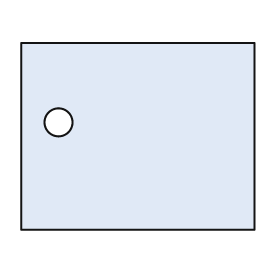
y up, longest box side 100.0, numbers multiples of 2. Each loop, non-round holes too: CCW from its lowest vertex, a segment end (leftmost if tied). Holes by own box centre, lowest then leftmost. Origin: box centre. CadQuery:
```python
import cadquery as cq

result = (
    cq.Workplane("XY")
    .moveTo(-50.0, -40.0)
    .lineTo(50.0, -40.0)
    .lineTo(50.0, 40.0)
    .lineTo(-50.0, 40.0)
    .close()
    .moveTo(-34.0, 6.0)
    .circle(6.0)
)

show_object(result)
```